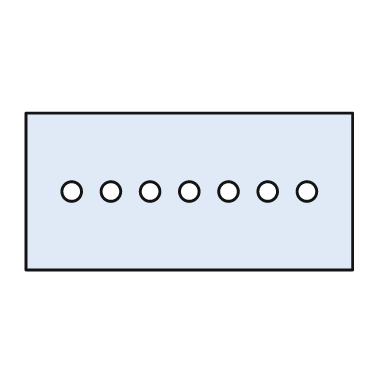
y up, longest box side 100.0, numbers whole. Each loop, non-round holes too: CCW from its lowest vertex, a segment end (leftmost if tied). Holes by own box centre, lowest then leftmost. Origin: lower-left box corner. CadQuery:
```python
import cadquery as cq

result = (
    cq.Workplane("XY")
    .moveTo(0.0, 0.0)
    .lineTo(100.0, 0.0)
    .lineTo(100.0, 48.0)
    .lineTo(0.0, 48.0)
    .close()
    .moveTo(14.0, 24.0)
    .circle(3.0)
    .moveTo(26.0, 24.0)
    .circle(3.0)
    .moveTo(38.0, 24.0)
    .circle(3.0)
    .moveTo(50.0, 24.0)
    .circle(3.0)
    .moveTo(62.0, 24.0)
    .circle(3.0)
    .moveTo(74.0, 24.0)
    .circle(3.0)
    .moveTo(86.0, 24.0)
    .circle(3.0)
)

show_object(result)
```